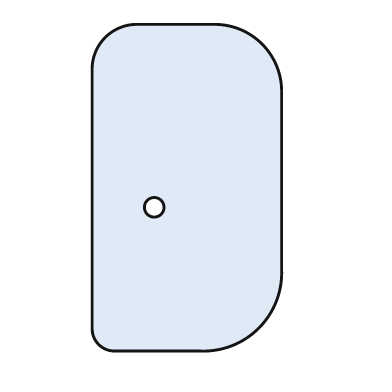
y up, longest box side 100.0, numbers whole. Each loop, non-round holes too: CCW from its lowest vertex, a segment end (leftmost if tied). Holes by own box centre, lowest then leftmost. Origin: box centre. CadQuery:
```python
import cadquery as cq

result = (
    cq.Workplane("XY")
    .moveTo(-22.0, -50.0)
    .lineTo(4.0, -50.0)
    .threePointArc((22.0, -43.0), (29.0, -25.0))
    .lineTo(29.0, 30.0)
    .threePointArc((23.0, 44.0), (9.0, 50.0))
    .lineTo(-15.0, 50.0)
    .threePointArc((-25.0, 46.0), (-29.0, 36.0))
    .lineTo(-29.0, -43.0)
    .threePointArc((-27.0, -48.0), (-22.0, -50.0))
    .close()
    .moveTo(-10.0, -6.0)
    .circle(3.0)
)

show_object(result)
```